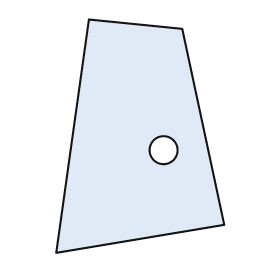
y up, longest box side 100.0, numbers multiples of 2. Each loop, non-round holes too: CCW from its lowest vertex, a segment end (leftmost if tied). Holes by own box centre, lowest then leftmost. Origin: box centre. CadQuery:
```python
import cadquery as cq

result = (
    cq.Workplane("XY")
    .moveTo(-36.0, -50.0)
    .lineTo(36.0, -38.0)
    .lineTo(18.0, 46.0)
    .lineTo(-22.0, 50.0)
    .close()
    .moveTo(10.0, -6.0)
    .circle(6.0)
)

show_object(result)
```